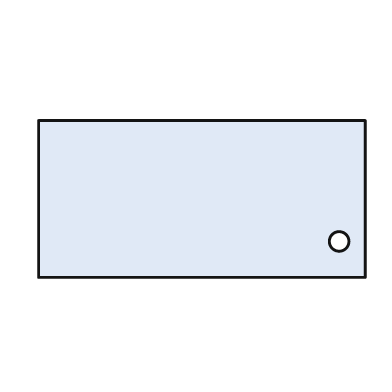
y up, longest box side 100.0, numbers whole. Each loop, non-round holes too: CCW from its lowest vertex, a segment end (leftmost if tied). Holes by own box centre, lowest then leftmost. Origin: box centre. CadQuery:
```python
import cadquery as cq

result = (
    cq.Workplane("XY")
    .moveTo(-50.0, -24.0)
    .lineTo(50.0, -24.0)
    .lineTo(50.0, 24.0)
    .lineTo(-50.0, 24.0)
    .close()
    .moveTo(42.0, -13.0)
    .circle(3.0)
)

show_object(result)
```